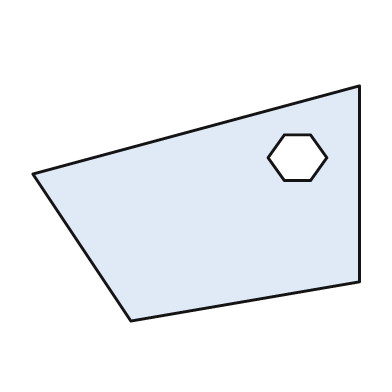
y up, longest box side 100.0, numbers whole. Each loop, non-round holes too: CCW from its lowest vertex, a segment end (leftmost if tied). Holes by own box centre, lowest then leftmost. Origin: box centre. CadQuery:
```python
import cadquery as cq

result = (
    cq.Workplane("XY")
    .moveTo(-20.0, -36.0)
    .lineTo(50.0, -24.0)
    .lineTo(50.0, 36.0)
    .lineTo(-50.0, 9.0)
    .close()
    .moveTo(27.0, 7.0)
    .lineTo(35.0, 7.0)
    .lineTo(40.0, 14.0)
    .lineTo(35.0, 21.0)
    .lineTo(27.0, 21.0)
    .lineTo(22.0, 14.0)
    .close()
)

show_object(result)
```